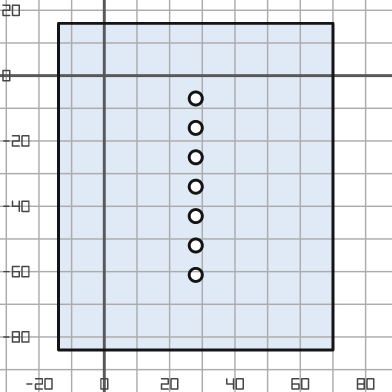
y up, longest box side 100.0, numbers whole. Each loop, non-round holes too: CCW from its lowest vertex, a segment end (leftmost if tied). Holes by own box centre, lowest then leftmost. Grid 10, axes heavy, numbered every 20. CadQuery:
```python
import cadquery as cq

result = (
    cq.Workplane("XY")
    .moveTo(-14.0, -84.0)
    .lineTo(70.0, -84.0)
    .lineTo(70.0, 16.0)
    .lineTo(-14.0, 16.0)
    .close()
    .moveTo(28.0, -61.0)
    .circle(2.0)
    .moveTo(28.0, -52.0)
    .circle(2.0)
    .moveTo(28.0, -43.0)
    .circle(2.0)
    .moveTo(28.0, -34.0)
    .circle(2.0)
    .moveTo(28.0, -25.0)
    .circle(2.0)
    .moveTo(28.0, -16.0)
    .circle(2.0)
    .moveTo(28.0, -7.0)
    .circle(2.0)
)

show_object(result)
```